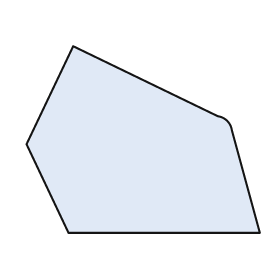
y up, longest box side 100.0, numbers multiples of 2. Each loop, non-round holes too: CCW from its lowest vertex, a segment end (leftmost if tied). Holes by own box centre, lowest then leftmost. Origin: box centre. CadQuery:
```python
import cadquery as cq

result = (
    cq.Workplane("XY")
    .moveTo(-32.0, -40.0)
    .lineTo(50.0, -40.0)
    .lineTo(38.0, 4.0)
    .threePointArc((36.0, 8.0), (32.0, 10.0))
    .lineTo(-30.0, 40.0)
    .lineTo(-50.0, -2.0)
    .close()
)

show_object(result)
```